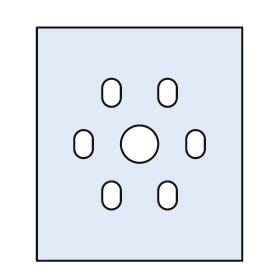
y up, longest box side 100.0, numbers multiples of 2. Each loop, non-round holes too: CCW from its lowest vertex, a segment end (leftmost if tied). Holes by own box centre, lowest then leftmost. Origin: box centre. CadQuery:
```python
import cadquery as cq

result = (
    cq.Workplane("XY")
    .moveTo(-44.0, -50.0)
    .lineTo(44.0, -50.0)
    .lineTo(44.0, 50.0)
    .lineTo(-44.0, 50.0)
    .close()
    .moveTo(-16.0, -24.0)
    .threePointArc((-12.0, -28.0), (-8.0, -24.0))
    .lineTo(-8.0, -20.0)
    .threePointArc((-12.0, -16.0), (-16.0, -20.0))
    .close()
    .moveTo(8.0, -24.0)
    .threePointArc((12.0, -28.0), (16.0, -24.0))
    .lineTo(16.0, -20.0)
    .threePointArc((12.0, -16.0), (8.0, -20.0))
    .close()
    .moveTo(-28.0, -2.0)
    .threePointArc((-24.0, -6.0), (-20.0, -2.0))
    .lineTo(-20.0, 2.0)
    .threePointArc((-24.0, 6.0), (-28.0, 2.0))
    .close()
    .moveTo(0.0, 0.0)
    .circle(8.0)
    .moveTo(20.0, -2.0)
    .threePointArc((24.0, -6.0), (28.0, -2.0))
    .lineTo(28.0, 2.0)
    .threePointArc((24.0, 6.0), (20.0, 2.0))
    .close()
    .moveTo(-16.0, 20.0)
    .threePointArc((-12.0, 16.0), (-8.0, 20.0))
    .lineTo(-8.0, 24.0)
    .threePointArc((-12.0, 28.0), (-16.0, 24.0))
    .close()
    .moveTo(8.0, 20.0)
    .threePointArc((12.0, 16.0), (16.0, 20.0))
    .lineTo(16.0, 24.0)
    .threePointArc((12.0, 28.0), (8.0, 24.0))
    .close()
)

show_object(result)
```